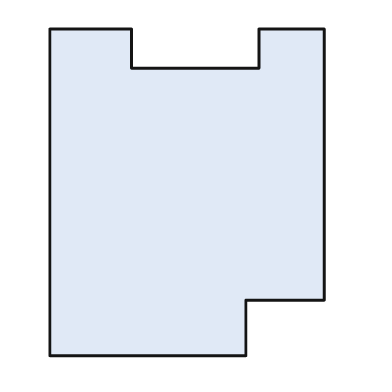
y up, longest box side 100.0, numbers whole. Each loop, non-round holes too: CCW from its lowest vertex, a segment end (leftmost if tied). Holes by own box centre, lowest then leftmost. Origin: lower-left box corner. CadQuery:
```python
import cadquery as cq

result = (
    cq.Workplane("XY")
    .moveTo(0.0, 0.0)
    .lineTo(60.0, 0.0)
    .lineTo(60.0, 17.0)
    .lineTo(84.0, 17.0)
    .lineTo(84.0, 100.0)
    .lineTo(64.0, 100.0)
    .lineTo(64.0, 88.0)
    .lineTo(25.0, 88.0)
    .lineTo(25.0, 100.0)
    .lineTo(0.0, 100.0)
    .close()
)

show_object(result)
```